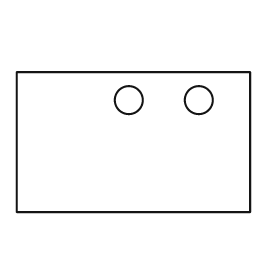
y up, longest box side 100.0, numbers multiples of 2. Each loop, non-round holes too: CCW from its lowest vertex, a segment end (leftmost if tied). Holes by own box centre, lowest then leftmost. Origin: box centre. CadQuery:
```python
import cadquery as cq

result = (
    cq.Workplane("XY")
    .moveTo(-50.0, -30.0)
    .lineTo(50.0, -30.0)
    .lineTo(50.0, 30.0)
    .lineTo(-50.0, 30.0)
    .close()
    .moveTo(-2.0, 18.0)
    .circle(6.0)
    .moveTo(28.0, 18.0)
    .circle(6.0)
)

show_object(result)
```